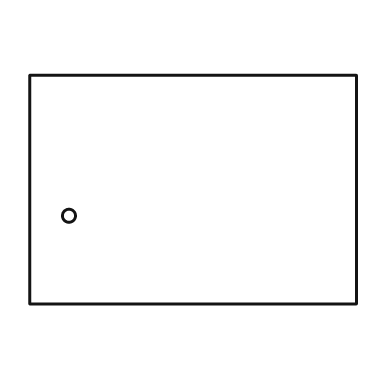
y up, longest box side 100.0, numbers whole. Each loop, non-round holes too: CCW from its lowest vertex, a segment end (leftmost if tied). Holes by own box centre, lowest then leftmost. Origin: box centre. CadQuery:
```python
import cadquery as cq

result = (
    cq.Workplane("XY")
    .moveTo(-50.0, -35.0)
    .lineTo(50.0, -35.0)
    .lineTo(50.0, 35.0)
    .lineTo(-50.0, 35.0)
    .close()
    .moveTo(-38.0, -8.0)
    .circle(2.0)
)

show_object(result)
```